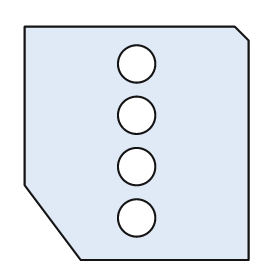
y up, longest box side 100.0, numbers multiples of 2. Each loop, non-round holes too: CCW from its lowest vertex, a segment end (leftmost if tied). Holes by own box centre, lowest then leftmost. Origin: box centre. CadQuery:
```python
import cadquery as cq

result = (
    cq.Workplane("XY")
    .moveTo(-24.0, -50.0)
    .lineTo(48.0, -50.0)
    .lineTo(48.0, 44.0)
    .lineTo(42.0, 50.0)
    .lineTo(-48.0, 50.0)
    .lineTo(-48.0, -18.0)
    .close()
    .moveTo(0.0, -32.0)
    .circle(8.0)
    .moveTo(0.0, -10.0)
    .circle(8.0)
    .moveTo(0.0, 12.0)
    .circle(8.0)
    .moveTo(0.0, 34.0)
    .circle(8.0)
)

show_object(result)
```